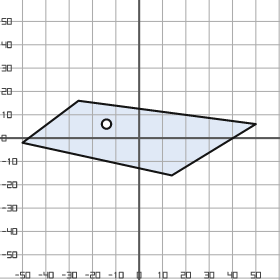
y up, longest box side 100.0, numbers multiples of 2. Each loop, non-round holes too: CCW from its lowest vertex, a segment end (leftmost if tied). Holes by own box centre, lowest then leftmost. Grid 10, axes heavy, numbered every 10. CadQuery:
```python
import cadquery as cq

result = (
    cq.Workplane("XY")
    .moveTo(14.0, -16.0)
    .lineTo(50.0, 6.0)
    .lineTo(-26.0, 16.0)
    .lineTo(-50.0, -2.0)
    .close()
    .moveTo(-14.0, 6.0)
    .circle(2.0)
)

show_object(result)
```